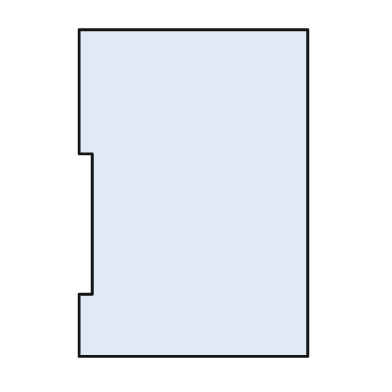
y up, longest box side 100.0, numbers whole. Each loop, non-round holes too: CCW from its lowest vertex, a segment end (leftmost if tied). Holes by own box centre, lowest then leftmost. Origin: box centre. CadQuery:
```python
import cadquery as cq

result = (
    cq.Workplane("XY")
    .moveTo(-35.0, -50.0)
    .lineTo(35.0, -50.0)
    .lineTo(35.0, 50.0)
    .lineTo(-35.0, 50.0)
    .lineTo(-35.0, 12.0)
    .lineTo(-31.0, 12.0)
    .lineTo(-31.0, -31.0)
    .lineTo(-35.0, -31.0)
    .close()
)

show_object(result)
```